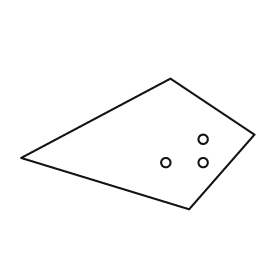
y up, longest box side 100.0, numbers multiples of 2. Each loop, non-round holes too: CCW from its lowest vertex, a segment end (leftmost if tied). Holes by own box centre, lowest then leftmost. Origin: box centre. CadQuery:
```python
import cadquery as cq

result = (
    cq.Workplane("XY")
    .moveTo(22.0, -28.0)
    .lineTo(50.0, 4.0)
    .lineTo(14.0, 28.0)
    .lineTo(-50.0, -6.0)
    .close()
    .moveTo(12.0, -8.0)
    .circle(2.0)
    .moveTo(28.0, -8.0)
    .circle(2.0)
    .moveTo(28.0, 2.0)
    .circle(2.0)
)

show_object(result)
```